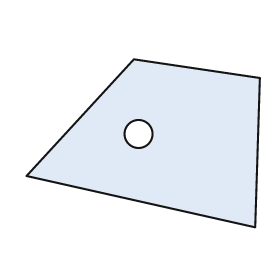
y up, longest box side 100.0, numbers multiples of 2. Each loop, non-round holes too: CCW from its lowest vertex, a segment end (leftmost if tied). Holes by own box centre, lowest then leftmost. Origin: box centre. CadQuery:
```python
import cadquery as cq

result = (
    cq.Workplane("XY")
    .moveTo(48.0, -36.0)
    .lineTo(50.0, 28.0)
    .lineTo(-4.0, 36.0)
    .lineTo(-50.0, -14.0)
    .close()
    .moveTo(-2.0, 4.0)
    .circle(6.0)
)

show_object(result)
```